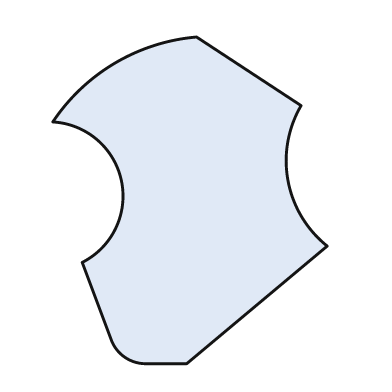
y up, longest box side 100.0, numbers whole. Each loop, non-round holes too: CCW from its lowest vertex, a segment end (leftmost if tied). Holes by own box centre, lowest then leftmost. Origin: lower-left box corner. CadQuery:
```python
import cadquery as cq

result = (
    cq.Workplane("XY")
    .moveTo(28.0, 0.0)
    .lineTo(41.0, 0.0)
    .lineTo(84.0, 36.0)
    .threePointArc((72.0, 56.0), (76.0, 79.0))
    .lineTo(44.0, 100.0)
    .threePointArc((19.0, 92.0), (0.0, 74.0))
    .threePointArc((21.0, 56.0), (9.0, 31.0))
    .lineTo(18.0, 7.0)
    .threePointArc((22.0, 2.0), (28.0, 0.0))
    .close()
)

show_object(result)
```